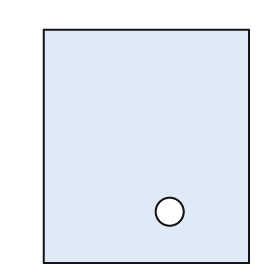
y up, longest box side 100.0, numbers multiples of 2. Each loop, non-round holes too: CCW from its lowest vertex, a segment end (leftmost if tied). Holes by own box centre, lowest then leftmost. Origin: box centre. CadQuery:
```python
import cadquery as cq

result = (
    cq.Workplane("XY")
    .moveTo(-44.0, -50.0)
    .lineTo(44.0, -50.0)
    .lineTo(44.0, 50.0)
    .lineTo(-44.0, 50.0)
    .close()
    .moveTo(10.0, -28.0)
    .circle(6.0)
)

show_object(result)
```